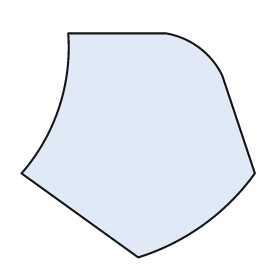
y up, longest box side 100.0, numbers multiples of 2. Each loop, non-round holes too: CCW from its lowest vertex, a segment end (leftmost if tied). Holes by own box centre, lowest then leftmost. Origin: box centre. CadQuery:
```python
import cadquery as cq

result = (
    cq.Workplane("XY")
    .moveTo(0.0, -48.0)
    .threePointArc((28.0, -34.0), (50.0, -12.0))
    .lineTo(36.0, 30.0)
    .threePointArc((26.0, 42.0), (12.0, 48.0))
    .lineTo(-30.0, 48.0)
    .threePointArc((-34.0, 16.0), (-50.0, -12.0))
    .close()
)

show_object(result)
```